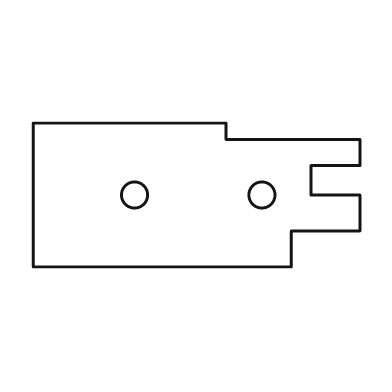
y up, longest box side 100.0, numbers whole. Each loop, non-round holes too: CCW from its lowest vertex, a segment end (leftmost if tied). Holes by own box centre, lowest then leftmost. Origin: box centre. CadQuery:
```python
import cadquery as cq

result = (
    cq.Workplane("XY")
    .moveTo(-50.0, -22.0)
    .lineTo(29.0, -22.0)
    .lineTo(29.0, -11.0)
    .lineTo(50.0, -11.0)
    .lineTo(50.0, 0.0)
    .lineTo(35.0, 0.0)
    .lineTo(35.0, 9.0)
    .lineTo(50.0, 9.0)
    .lineTo(50.0, 17.0)
    .lineTo(9.0, 17.0)
    .lineTo(9.0, 22.0)
    .lineTo(-50.0, 22.0)
    .close()
    .moveTo(-19.0, 0.0)
    .circle(4.0)
    .moveTo(20.0, 0.0)
    .circle(4.0)
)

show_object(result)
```